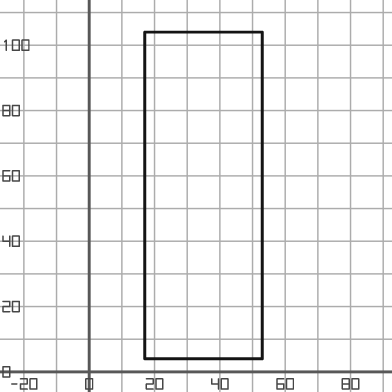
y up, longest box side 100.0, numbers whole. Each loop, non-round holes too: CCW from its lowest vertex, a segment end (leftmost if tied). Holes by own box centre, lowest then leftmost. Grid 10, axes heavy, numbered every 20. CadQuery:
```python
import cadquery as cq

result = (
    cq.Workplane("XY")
    .moveTo(17.0, 4.0)
    .lineTo(53.0, 4.0)
    .lineTo(53.0, 104.0)
    .lineTo(17.0, 104.0)
    .close()
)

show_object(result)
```